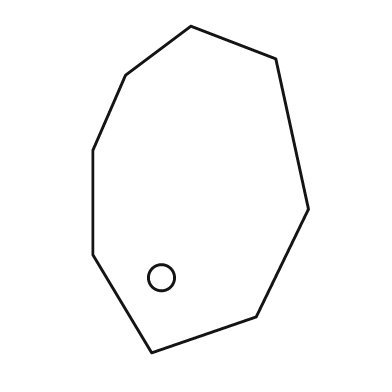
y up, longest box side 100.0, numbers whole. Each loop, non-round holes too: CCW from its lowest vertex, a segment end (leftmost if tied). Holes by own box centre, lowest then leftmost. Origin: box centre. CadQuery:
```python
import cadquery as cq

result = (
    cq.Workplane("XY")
    .moveTo(-15.0, -50.0)
    .lineTo(17.0, -39.0)
    .lineTo(33.0, -6.0)
    .lineTo(23.0, 40.0)
    .lineTo(-3.0, 50.0)
    .lineTo(-23.0, 35.0)
    .lineTo(-33.0, 12.0)
    .lineTo(-33.0, -20.0)
    .close()
    .moveTo(-12.0, -27.0)
    .circle(4.0)
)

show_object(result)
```